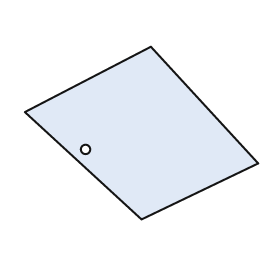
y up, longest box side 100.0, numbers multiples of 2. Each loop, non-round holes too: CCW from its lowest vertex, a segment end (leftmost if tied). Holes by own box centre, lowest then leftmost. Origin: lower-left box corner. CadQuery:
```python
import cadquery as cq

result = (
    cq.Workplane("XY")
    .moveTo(50.0, 0.0)
    .lineTo(100.0, 24.0)
    .lineTo(54.0, 74.0)
    .lineTo(0.0, 46.0)
    .close()
    .moveTo(26.0, 30.0)
    .circle(2.0)
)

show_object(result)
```